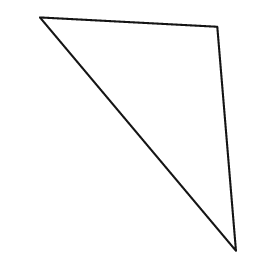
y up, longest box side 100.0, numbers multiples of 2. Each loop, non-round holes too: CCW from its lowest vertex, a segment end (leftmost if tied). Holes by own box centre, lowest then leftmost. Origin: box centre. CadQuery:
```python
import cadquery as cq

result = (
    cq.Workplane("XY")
    .moveTo(42.0, -50.0)
    .lineTo(34.0, 46.0)
    .lineTo(-42.0, 50.0)
    .close()
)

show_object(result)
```